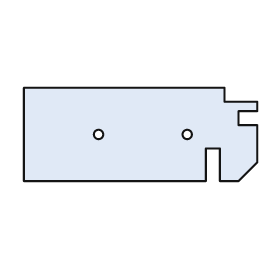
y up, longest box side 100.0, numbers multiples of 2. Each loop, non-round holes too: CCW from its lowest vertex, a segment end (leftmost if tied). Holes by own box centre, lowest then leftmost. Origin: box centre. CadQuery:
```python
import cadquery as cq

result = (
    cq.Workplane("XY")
    .moveTo(-50.0, -20.0)
    .lineTo(28.0, -20.0)
    .lineTo(28.0, -6.0)
    .lineTo(34.0, -6.0)
    .lineTo(34.0, -20.0)
    .lineTo(42.0, -20.0)
    .lineTo(50.0, -12.0)
    .lineTo(50.0, 4.0)
    .lineTo(42.0, 4.0)
    .lineTo(42.0, 10.0)
    .lineTo(50.0, 10.0)
    .lineTo(50.0, 14.0)
    .lineTo(36.0, 14.0)
    .lineTo(36.0, 20.0)
    .lineTo(-50.0, 20.0)
    .close()
    .moveTo(-18.0, 0.0)
    .circle(2.0)
    .moveTo(20.0, 0.0)
    .circle(2.0)
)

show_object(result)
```